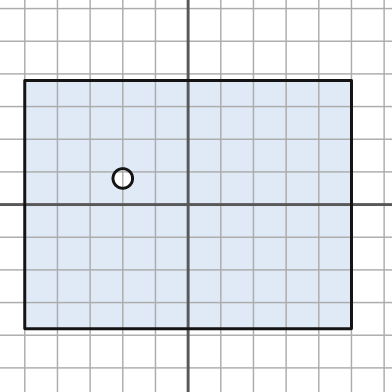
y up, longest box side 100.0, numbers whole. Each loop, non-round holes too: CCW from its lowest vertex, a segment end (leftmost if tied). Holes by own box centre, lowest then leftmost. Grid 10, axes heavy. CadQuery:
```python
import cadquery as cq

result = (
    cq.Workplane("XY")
    .moveTo(-50.0, -38.0)
    .lineTo(50.0, -38.0)
    .lineTo(50.0, 38.0)
    .lineTo(-50.0, 38.0)
    .close()
    .moveTo(-20.0, 8.0)
    .circle(3.0)
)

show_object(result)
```